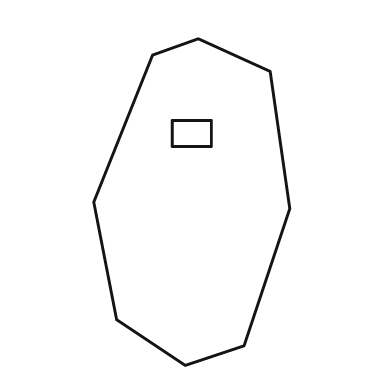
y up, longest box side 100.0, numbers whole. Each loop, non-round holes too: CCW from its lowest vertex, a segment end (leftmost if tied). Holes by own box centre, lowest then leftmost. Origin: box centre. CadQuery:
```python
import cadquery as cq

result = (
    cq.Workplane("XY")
    .moveTo(-2.0, -50.0)
    .lineTo(16.0, -44.0)
    .lineTo(30.0, -2.0)
    .lineTo(24.0, 40.0)
    .lineTo(2.0, 50.0)
    .lineTo(-12.0, 45.0)
    .lineTo(-30.0, 0.0)
    .lineTo(-23.0, -36.0)
    .close()
    .moveTo(-6.0, 17.0)
    .lineTo(6.0, 17.0)
    .lineTo(6.0, 25.0)
    .lineTo(-6.0, 25.0)
    .close()
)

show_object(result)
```